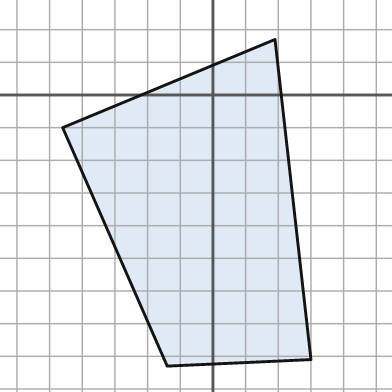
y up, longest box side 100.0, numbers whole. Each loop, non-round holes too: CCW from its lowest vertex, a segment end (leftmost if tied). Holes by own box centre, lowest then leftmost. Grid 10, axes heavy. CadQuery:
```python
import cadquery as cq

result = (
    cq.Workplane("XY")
    .moveTo(-14.0, -83.0)
    .lineTo(30.0, -81.0)
    .lineTo(19.0, 17.0)
    .lineTo(-46.0, -10.0)
    .close()
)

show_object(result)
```